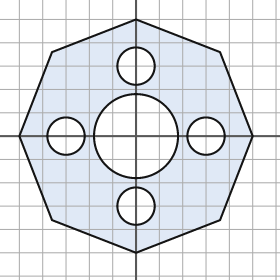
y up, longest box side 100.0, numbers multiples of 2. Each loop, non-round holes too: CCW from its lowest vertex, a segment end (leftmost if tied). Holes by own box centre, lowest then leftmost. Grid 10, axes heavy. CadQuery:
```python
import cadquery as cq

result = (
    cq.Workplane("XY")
    .moveTo(0.0, -50.0)
    .lineTo(36.0, -36.0)
    .lineTo(50.0, 0.0)
    .lineTo(36.0, 36.0)
    .lineTo(0.0, 50.0)
    .lineTo(-36.0, 36.0)
    .lineTo(-50.0, 0.0)
    .lineTo(-36.0, -36.0)
    .close()
    .moveTo(0.0, -30.0)
    .circle(8.0)
    .moveTo(-30.0, 0.0)
    .circle(8.0)
    .moveTo(0.0, 0.0)
    .circle(18.0)
    .moveTo(30.0, 0.0)
    .circle(8.0)
    .moveTo(0.0, 30.0)
    .circle(8.0)
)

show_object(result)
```